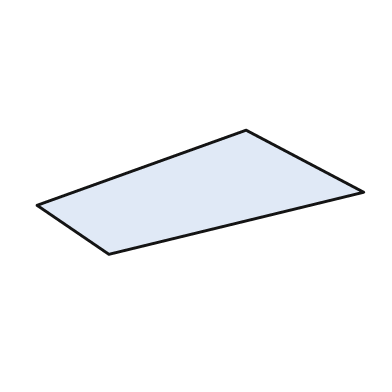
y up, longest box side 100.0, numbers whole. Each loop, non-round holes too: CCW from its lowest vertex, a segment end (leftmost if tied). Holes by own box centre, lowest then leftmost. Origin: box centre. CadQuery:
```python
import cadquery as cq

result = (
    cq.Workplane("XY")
    .moveTo(-28.0, -19.0)
    .lineTo(50.0, 0.0)
    .lineTo(14.0, 19.0)
    .lineTo(-50.0, -4.0)
    .close()
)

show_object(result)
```